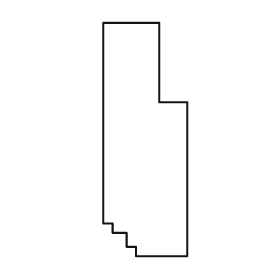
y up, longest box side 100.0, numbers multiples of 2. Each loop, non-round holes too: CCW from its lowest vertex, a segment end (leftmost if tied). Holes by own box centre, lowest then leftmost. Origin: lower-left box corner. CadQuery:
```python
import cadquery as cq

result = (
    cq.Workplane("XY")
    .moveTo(14.0, 0.0)
    .lineTo(36.0, 0.0)
    .lineTo(36.0, 66.0)
    .lineTo(24.0, 66.0)
    .lineTo(24.0, 100.0)
    .lineTo(0.0, 100.0)
    .lineTo(0.0, 14.0)
    .lineTo(4.0, 14.0)
    .lineTo(4.0, 10.0)
    .lineTo(10.0, 10.0)
    .lineTo(10.0, 4.0)
    .lineTo(14.0, 4.0)
    .close()
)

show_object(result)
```